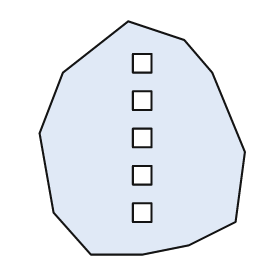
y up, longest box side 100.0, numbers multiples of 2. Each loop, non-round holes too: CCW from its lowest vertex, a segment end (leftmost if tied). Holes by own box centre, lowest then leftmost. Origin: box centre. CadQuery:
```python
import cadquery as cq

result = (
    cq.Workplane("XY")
    .moveTo(-22.0, -50.0)
    .lineTo(0.0, -50.0)
    .lineTo(20.0, -46.0)
    .lineTo(40.0, -36.0)
    .lineTo(44.0, -6.0)
    .lineTo(30.0, 28.0)
    .lineTo(18.0, 42.0)
    .lineTo(-6.0, 50.0)
    .lineTo(-34.0, 28.0)
    .lineTo(-44.0, 2.0)
    .lineTo(-38.0, -32.0)
    .close()
    .moveTo(-4.0, -36.0)
    .lineTo(4.0, -36.0)
    .lineTo(4.0, -28.0)
    .lineTo(-4.0, -28.0)
    .close()
    .moveTo(-4.0, -20.0)
    .lineTo(4.0, -20.0)
    .lineTo(4.0, -12.0)
    .lineTo(-4.0, -12.0)
    .close()
    .moveTo(-4.0, -4.0)
    .lineTo(4.0, -4.0)
    .lineTo(4.0, 4.0)
    .lineTo(-4.0, 4.0)
    .close()
    .moveTo(-4.0, 12.0)
    .lineTo(4.0, 12.0)
    .lineTo(4.0, 20.0)
    .lineTo(-4.0, 20.0)
    .close()
    .moveTo(-4.0, 28.0)
    .lineTo(4.0, 28.0)
    .lineTo(4.0, 36.0)
    .lineTo(-4.0, 36.0)
    .close()
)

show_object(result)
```